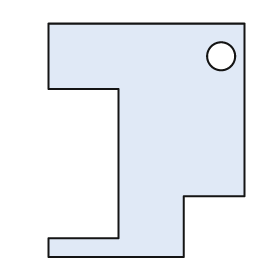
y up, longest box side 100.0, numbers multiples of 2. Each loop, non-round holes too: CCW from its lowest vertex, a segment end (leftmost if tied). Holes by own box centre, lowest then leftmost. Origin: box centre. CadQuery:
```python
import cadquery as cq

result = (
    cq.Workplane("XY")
    .moveTo(-42.0, -50.0)
    .lineTo(16.0, -50.0)
    .lineTo(16.0, -24.0)
    .lineTo(42.0, -24.0)
    .lineTo(42.0, 50.0)
    .lineTo(-42.0, 50.0)
    .lineTo(-42.0, 22.0)
    .lineTo(-12.0, 22.0)
    .lineTo(-12.0, -42.0)
    .lineTo(-42.0, -42.0)
    .close()
    .moveTo(32.0, 36.0)
    .circle(6.0)
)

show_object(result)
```